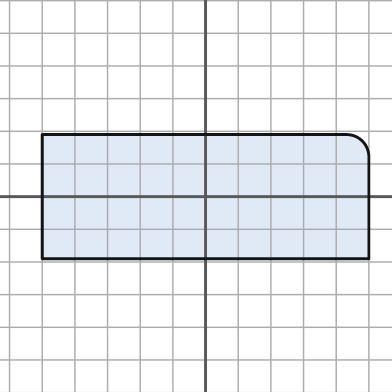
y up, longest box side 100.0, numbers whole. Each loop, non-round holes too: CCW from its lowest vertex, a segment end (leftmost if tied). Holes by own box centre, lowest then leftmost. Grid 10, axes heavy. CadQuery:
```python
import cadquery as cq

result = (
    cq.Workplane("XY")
    .moveTo(-50.0, -19.0)
    .lineTo(50.0, -19.0)
    .lineTo(50.0, 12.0)
    .threePointArc((48.0, 17.0), (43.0, 19.0))
    .lineTo(-50.0, 19.0)
    .close()
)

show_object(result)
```